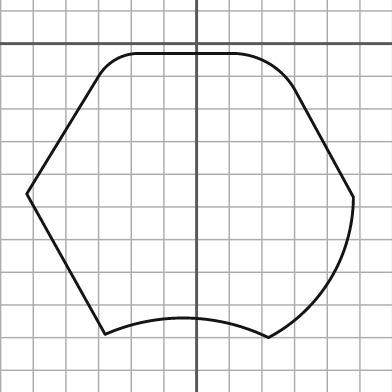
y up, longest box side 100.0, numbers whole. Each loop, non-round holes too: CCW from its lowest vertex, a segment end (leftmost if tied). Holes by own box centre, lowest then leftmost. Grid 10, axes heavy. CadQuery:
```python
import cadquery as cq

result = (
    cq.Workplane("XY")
    .moveTo(22.0, -90.0)
    .threePointArc((41.0, -72.0), (48.0, -47.0))
    .lineTo(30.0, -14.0)
    .threePointArc((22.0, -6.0), (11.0, -3.0))
    .lineTo(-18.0, -3.0)
    .threePointArc((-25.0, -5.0), (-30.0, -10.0))
    .lineTo(-52.0, -46.0)
    .lineTo(-28.0, -89.0)
    .threePointArc((-3.0, -84.0), (22.0, -90.0))
    .close()
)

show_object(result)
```